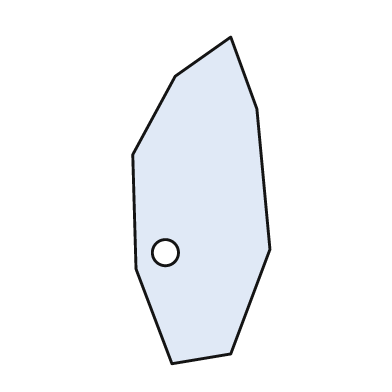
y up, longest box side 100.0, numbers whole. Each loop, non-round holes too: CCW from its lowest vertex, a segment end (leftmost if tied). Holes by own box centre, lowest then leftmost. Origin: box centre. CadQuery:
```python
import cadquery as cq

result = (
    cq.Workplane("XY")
    .moveTo(-9.0, -50.0)
    .lineTo(9.0, -47.0)
    .lineTo(21.0, -15.0)
    .lineTo(17.0, 28.0)
    .lineTo(9.0, 50.0)
    .lineTo(-8.0, 38.0)
    .lineTo(-21.0, 14.0)
    .lineTo(-20.0, -21.0)
    .close()
    .moveTo(-11.0, -16.0)
    .circle(4.0)
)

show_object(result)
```